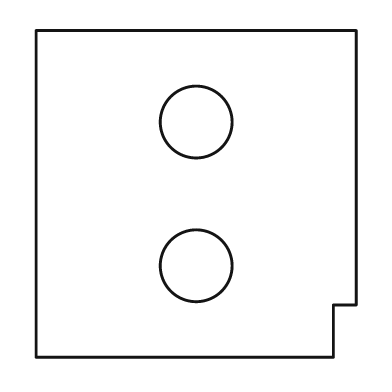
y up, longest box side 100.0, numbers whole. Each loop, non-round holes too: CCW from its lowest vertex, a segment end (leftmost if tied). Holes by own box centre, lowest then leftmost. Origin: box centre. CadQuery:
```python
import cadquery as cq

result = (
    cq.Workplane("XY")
    .moveTo(-49.0, -50.0)
    .lineTo(42.0, -50.0)
    .lineTo(42.0, -34.0)
    .lineTo(49.0, -34.0)
    .lineTo(49.0, 50.0)
    .lineTo(-49.0, 50.0)
    .close()
    .moveTo(0.0, -22.0)
    .circle(11.0)
    .moveTo(0.0, 22.0)
    .circle(11.0)
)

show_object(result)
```